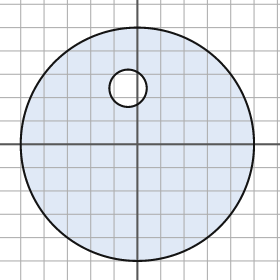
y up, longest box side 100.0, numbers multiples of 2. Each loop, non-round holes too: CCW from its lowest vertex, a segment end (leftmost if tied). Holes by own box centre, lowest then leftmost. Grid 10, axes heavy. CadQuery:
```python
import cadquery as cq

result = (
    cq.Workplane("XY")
    .moveTo(0.0, 0.0)
    .circle(50.0)
    .moveTo(-4.0, 24.0)
    .circle(8.0)
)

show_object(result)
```